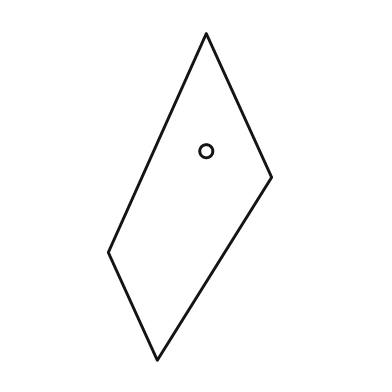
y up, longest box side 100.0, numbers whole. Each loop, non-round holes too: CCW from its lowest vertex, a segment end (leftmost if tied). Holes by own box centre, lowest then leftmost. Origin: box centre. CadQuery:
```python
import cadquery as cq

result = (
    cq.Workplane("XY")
    .moveTo(-10.0, -50.0)
    .lineTo(25.0, 6.0)
    .lineTo(5.0, 50.0)
    .lineTo(-25.0, -17.0)
    .close()
    .moveTo(5.0, 14.0)
    .circle(2.0)
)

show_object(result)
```